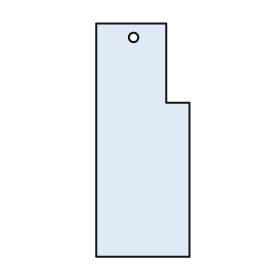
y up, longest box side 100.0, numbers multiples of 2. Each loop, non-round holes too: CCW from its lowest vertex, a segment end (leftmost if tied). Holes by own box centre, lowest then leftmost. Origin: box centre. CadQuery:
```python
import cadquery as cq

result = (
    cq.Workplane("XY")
    .moveTo(-20.0, -50.0)
    .lineTo(20.0, -50.0)
    .lineTo(20.0, 16.0)
    .lineTo(10.0, 16.0)
    .lineTo(10.0, 50.0)
    .lineTo(-20.0, 50.0)
    .close()
    .moveTo(-4.0, 44.0)
    .circle(2.0)
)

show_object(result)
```